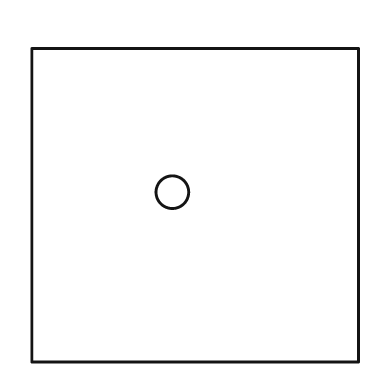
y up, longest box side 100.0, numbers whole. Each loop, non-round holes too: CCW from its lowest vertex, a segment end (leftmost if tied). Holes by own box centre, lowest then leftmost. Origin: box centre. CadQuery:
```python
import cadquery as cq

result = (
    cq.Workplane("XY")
    .moveTo(-50.0, -48.0)
    .lineTo(50.0, -48.0)
    .lineTo(50.0, 48.0)
    .lineTo(-50.0, 48.0)
    .close()
    .moveTo(-7.0, 4.0)
    .circle(5.0)
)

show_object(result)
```